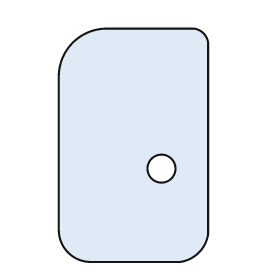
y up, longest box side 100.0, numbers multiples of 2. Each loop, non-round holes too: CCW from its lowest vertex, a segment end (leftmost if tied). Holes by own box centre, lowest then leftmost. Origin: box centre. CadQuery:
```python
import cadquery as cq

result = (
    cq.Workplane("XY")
    .moveTo(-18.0, -50.0)
    .lineTo(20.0, -50.0)
    .threePointArc((28.0, -46.0), (32.0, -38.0))
    .lineTo(32.0, 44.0)
    .threePointArc((30.0, 48.0), (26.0, 50.0))
    .lineTo(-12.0, 50.0)
    .threePointArc((-26.0, 44.0), (-32.0, 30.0))
    .lineTo(-32.0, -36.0)
    .threePointArc((-28.0, -46.0), (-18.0, -50.0))
    .close()
    .moveTo(12.0, -10.0)
    .circle(6.0)
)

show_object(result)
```